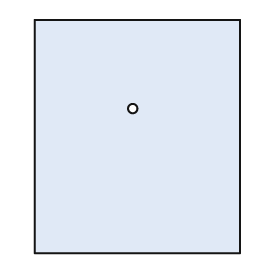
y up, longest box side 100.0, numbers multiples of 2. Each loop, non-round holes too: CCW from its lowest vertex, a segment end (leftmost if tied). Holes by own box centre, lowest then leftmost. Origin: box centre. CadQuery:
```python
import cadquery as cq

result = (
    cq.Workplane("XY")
    .moveTo(-44.0, -50.0)
    .lineTo(44.0, -50.0)
    .lineTo(44.0, 50.0)
    .lineTo(-44.0, 50.0)
    .close()
    .moveTo(-2.0, 12.0)
    .circle(2.0)
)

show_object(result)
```